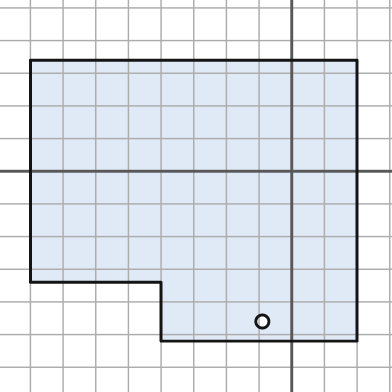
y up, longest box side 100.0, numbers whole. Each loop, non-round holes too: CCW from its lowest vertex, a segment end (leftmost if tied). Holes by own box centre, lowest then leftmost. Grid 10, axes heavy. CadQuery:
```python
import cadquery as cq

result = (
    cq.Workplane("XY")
    .moveTo(-40.0, -52.0)
    .lineTo(20.0, -52.0)
    .lineTo(20.0, 34.0)
    .lineTo(-80.0, 34.0)
    .lineTo(-80.0, -34.0)
    .lineTo(-40.0, -34.0)
    .close()
    .moveTo(-9.0, -46.0)
    .circle(2.0)
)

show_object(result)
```